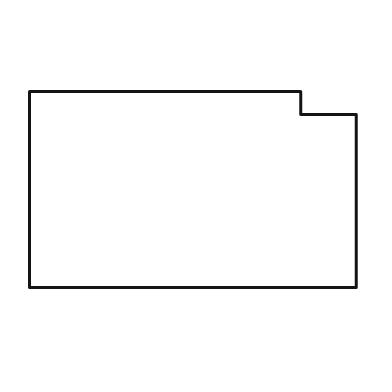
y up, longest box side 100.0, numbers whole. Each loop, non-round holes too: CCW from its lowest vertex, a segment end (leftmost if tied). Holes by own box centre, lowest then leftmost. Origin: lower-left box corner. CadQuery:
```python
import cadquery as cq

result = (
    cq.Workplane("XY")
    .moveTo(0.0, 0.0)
    .lineTo(100.0, 0.0)
    .lineTo(100.0, 53.0)
    .lineTo(83.0, 53.0)
    .lineTo(83.0, 60.0)
    .lineTo(0.0, 60.0)
    .close()
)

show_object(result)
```